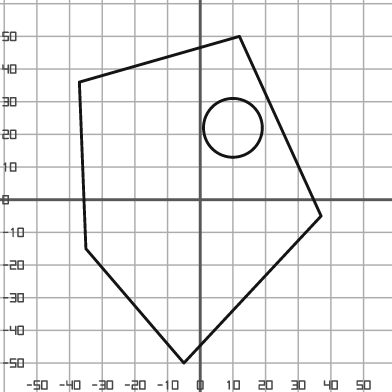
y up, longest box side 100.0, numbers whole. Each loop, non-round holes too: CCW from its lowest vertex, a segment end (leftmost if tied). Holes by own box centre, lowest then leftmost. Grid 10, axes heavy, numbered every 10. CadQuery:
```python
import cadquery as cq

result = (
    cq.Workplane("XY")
    .moveTo(-5.0, -50.0)
    .lineTo(37.0, -5.0)
    .lineTo(12.0, 50.0)
    .lineTo(-37.0, 36.0)
    .lineTo(-35.0, -15.0)
    .close()
    .moveTo(10.0, 22.0)
    .circle(9.0)
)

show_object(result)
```